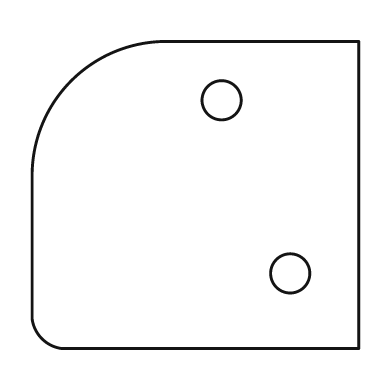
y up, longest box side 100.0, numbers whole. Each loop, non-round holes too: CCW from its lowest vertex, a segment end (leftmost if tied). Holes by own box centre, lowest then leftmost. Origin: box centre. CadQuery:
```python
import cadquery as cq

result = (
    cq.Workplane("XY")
    .moveTo(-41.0, -47.0)
    .lineTo(50.0, -47.0)
    .lineTo(50.0, 47.0)
    .lineTo(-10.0, 47.0)
    .threePointArc((-38.0, 35.0), (-50.0, 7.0))
    .lineTo(-50.0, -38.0)
    .threePointArc((-47.0, -44.0), (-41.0, -47.0))
    .close()
    .moveTo(29.0, -24.0)
    .circle(6.0)
    .moveTo(8.0, 29.0)
    .circle(6.0)
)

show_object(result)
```